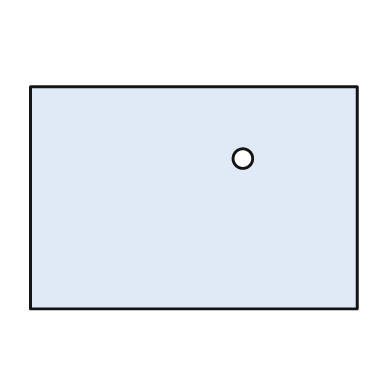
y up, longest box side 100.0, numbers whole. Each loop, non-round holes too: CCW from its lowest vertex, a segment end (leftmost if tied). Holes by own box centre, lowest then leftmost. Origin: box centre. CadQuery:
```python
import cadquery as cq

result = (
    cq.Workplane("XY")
    .moveTo(-50.0, -34.0)
    .lineTo(50.0, -34.0)
    .lineTo(50.0, 34.0)
    .lineTo(-50.0, 34.0)
    .close()
    .moveTo(15.0, 12.0)
    .circle(3.0)
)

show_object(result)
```